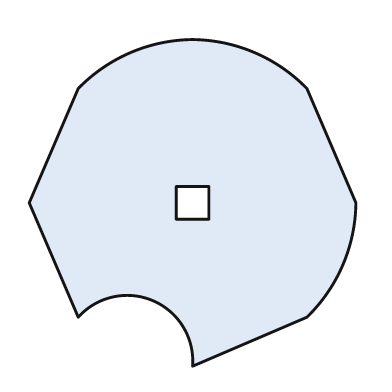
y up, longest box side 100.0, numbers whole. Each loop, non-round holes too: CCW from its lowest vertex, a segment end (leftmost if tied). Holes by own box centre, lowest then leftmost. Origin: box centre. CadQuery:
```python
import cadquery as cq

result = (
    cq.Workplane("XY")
    .moveTo(0.0, -50.0)
    .lineTo(35.0, -35.0)
    .threePointArc((46.0, -19.0), (50.0, 0.0))
    .lineTo(35.0, 35.0)
    .threePointArc((19.0, 46.0), (0.0, 50.0))
    .threePointArc((-19.0, 46.0), (-35.0, 35.0))
    .lineTo(-50.0, 0.0)
    .lineTo(-35.0, -35.0)
    .threePointArc((-12.0, -30.0), (0.0, -50.0))
    .close()
    .moveTo(-5.0, -5.0)
    .lineTo(5.0, -5.0)
    .lineTo(5.0, 5.0)
    .lineTo(-5.0, 5.0)
    .close()
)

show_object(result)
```